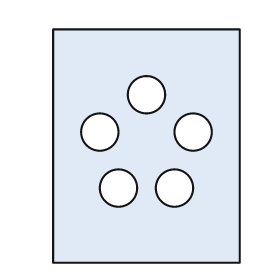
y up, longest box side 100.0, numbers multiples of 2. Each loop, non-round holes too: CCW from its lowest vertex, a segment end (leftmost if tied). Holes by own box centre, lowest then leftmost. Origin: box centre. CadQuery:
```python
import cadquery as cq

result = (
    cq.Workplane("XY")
    .moveTo(-40.0, -50.0)
    .lineTo(40.0, -50.0)
    .lineTo(40.0, 50.0)
    .lineTo(-40.0, 50.0)
    .close()
    .moveTo(-12.0, -18.0)
    .circle(8.0)
    .moveTo(12.0, -18.0)
    .circle(8.0)
    .moveTo(-20.0, 6.0)
    .circle(8.0)
    .moveTo(20.0, 6.0)
    .circle(8.0)
    .moveTo(0.0, 22.0)
    .circle(8.0)
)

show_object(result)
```